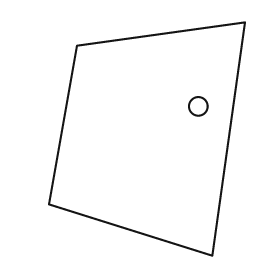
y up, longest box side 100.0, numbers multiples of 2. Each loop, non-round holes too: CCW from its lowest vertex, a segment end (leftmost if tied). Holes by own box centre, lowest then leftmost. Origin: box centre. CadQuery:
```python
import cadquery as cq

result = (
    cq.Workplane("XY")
    .moveTo(28.0, -50.0)
    .lineTo(42.0, 50.0)
    .lineTo(-30.0, 40.0)
    .lineTo(-42.0, -28.0)
    .close()
    .moveTo(22.0, 14.0)
    .circle(4.0)
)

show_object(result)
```